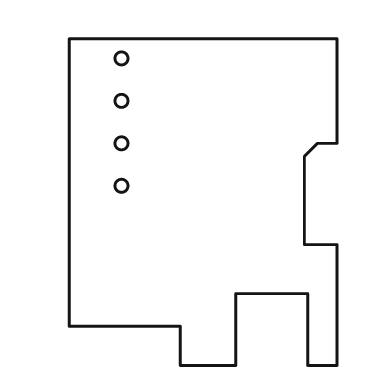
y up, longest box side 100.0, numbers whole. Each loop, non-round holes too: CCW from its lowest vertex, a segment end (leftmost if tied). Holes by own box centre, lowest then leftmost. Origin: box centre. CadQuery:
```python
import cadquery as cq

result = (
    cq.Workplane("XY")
    .moveTo(-7.0, -50.0)
    .lineTo(10.0, -50.0)
    .lineTo(10.0, -28.0)
    .lineTo(32.0, -28.0)
    .lineTo(32.0, -50.0)
    .lineTo(41.0, -50.0)
    .lineTo(41.0, -13.0)
    .lineTo(31.0, -13.0)
    .lineTo(31.0, 14.0)
    .lineTo(35.0, 18.0)
    .lineTo(41.0, 18.0)
    .lineTo(41.0, 50.0)
    .lineTo(-41.0, 50.0)
    .lineTo(-41.0, -38.0)
    .lineTo(-7.0, -38.0)
    .close()
    .moveTo(-25.0, 5.0)
    .circle(2.0)
    .moveTo(-25.0, 18.0)
    .circle(2.0)
    .moveTo(-25.0, 31.0)
    .circle(2.0)
    .moveTo(-25.0, 44.0)
    .circle(2.0)
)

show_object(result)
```